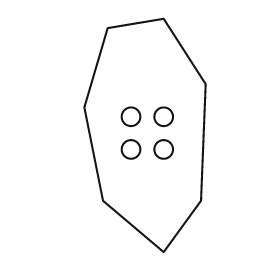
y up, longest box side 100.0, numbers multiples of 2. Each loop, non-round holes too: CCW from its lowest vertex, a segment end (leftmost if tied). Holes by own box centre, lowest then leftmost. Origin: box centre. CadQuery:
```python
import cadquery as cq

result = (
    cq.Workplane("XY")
    .moveTo(8.0, -50.0)
    .lineTo(24.0, -28.0)
    .lineTo(26.0, 22.0)
    .lineTo(8.0, 50.0)
    .lineTo(-16.0, 46.0)
    .lineTo(-26.0, 12.0)
    .lineTo(-18.0, -28.0)
    .close()
    .moveTo(-6.0, -6.0)
    .circle(4.0)
    .moveTo(8.0, -6.0)
    .circle(4.0)
    .moveTo(-6.0, 8.0)
    .circle(4.0)
    .moveTo(8.0, 8.0)
    .circle(4.0)
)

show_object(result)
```